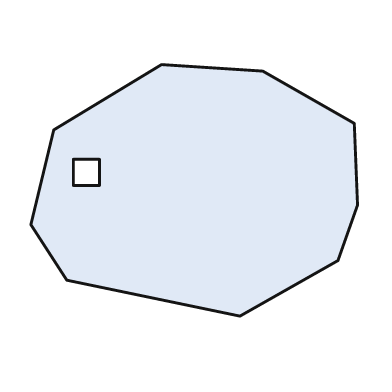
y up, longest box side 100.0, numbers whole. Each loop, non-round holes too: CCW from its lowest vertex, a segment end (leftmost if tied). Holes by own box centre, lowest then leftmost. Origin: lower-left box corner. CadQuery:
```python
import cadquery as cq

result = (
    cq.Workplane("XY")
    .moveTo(64.0, 0.0)
    .lineTo(94.0, 17.0)
    .lineTo(100.0, 34.0)
    .lineTo(99.0, 59.0)
    .lineTo(71.0, 75.0)
    .lineTo(40.0, 77.0)
    .lineTo(7.0, 57.0)
    .lineTo(0.0, 28.0)
    .lineTo(11.0, 11.0)
    .close()
    .moveTo(13.0, 40.0)
    .lineTo(21.0, 40.0)
    .lineTo(21.0, 48.0)
    .lineTo(13.0, 48.0)
    .close()
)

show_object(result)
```